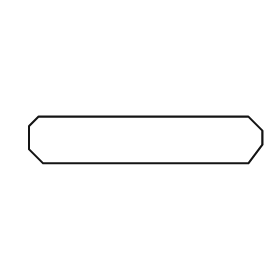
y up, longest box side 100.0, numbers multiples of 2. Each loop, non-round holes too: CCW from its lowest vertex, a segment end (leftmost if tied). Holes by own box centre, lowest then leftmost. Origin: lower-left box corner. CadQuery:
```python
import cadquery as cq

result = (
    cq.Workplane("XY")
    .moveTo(6.0, 0.0)
    .lineTo(94.0, 0.0)
    .lineTo(100.0, 8.0)
    .lineTo(100.0, 14.0)
    .lineTo(94.0, 20.0)
    .lineTo(4.0, 20.0)
    .lineTo(0.0, 16.0)
    .lineTo(0.0, 6.0)
    .close()
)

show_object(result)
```